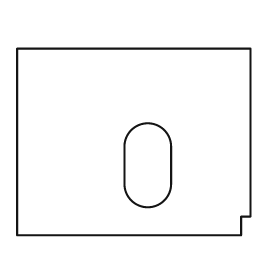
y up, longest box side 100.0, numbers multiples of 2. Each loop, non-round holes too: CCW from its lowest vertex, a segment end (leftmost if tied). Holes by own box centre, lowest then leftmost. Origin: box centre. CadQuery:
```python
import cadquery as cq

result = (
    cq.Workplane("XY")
    .moveTo(-50.0, -40.0)
    .lineTo(46.0, -40.0)
    .lineTo(46.0, -32.0)
    .lineTo(50.0, -32.0)
    .lineTo(50.0, 40.0)
    .lineTo(-50.0, 40.0)
    .close()
    .moveTo(-4.0, -18.0)
    .threePointArc((6.0, -28.0), (16.0, -18.0))
    .lineTo(16.0, -2.0)
    .threePointArc((6.0, 8.0), (-4.0, -2.0))
    .close()
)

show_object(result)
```